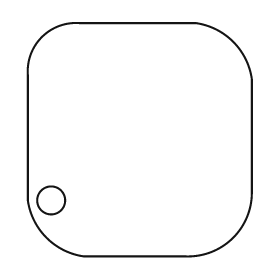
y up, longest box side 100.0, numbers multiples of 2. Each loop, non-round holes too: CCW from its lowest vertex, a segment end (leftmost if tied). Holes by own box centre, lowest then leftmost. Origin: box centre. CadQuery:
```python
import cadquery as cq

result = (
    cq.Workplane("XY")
    .moveTo(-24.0, -50.0)
    .lineTo(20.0, -50.0)
    .threePointArc((40.0, -42.0), (48.0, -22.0))
    .lineTo(48.0, 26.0)
    .threePointArc((40.0, 42.0), (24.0, 50.0))
    .lineTo(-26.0, 50.0)
    .threePointArc((-42.0, 44.0), (-48.0, 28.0))
    .lineTo(-48.0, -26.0)
    .threePointArc((-40.0, -42.0), (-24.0, -50.0))
    .close()
    .moveTo(-38.0, -26.0)
    .circle(6.0)
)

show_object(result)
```